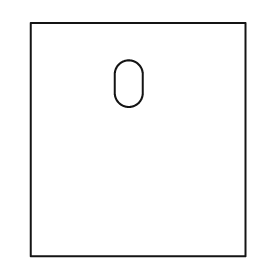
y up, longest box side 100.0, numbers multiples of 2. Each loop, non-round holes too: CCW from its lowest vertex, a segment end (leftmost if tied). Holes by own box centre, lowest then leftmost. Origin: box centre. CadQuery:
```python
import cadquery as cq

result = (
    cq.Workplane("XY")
    .moveTo(-46.0, -50.0)
    .lineTo(46.0, -50.0)
    .lineTo(46.0, 50.0)
    .lineTo(-46.0, 50.0)
    .close()
    .moveTo(-10.0, 20.0)
    .threePointArc((-4.0, 14.0), (2.0, 20.0))
    .lineTo(2.0, 28.0)
    .threePointArc((-4.0, 34.0), (-10.0, 28.0))
    .close()
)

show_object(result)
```